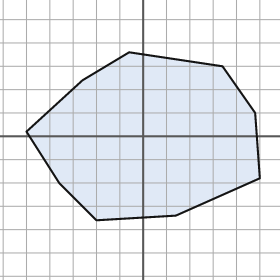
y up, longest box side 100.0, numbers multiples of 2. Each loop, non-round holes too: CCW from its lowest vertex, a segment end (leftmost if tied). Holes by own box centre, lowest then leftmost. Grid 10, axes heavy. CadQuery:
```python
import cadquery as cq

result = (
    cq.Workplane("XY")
    .moveTo(-20.0, -36.0)
    .lineTo(14.0, -34.0)
    .lineTo(50.0, -18.0)
    .lineTo(48.0, 10.0)
    .lineTo(34.0, 30.0)
    .lineTo(-6.0, 36.0)
    .lineTo(-26.0, 24.0)
    .lineTo(-50.0, 2.0)
    .lineTo(-36.0, -20.0)
    .close()
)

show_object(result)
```